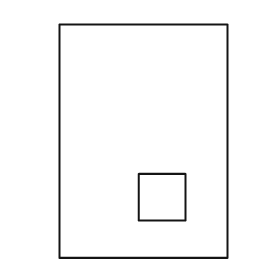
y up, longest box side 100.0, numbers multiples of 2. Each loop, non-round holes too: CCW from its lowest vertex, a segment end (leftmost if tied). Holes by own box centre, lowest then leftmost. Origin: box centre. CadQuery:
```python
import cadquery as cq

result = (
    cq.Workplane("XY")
    .moveTo(-36.0, -50.0)
    .lineTo(36.0, -50.0)
    .lineTo(36.0, 50.0)
    .lineTo(-36.0, 50.0)
    .close()
    .moveTo(-2.0, -34.0)
    .lineTo(18.0, -34.0)
    .lineTo(18.0, -14.0)
    .lineTo(-2.0, -14.0)
    .close()
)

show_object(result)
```